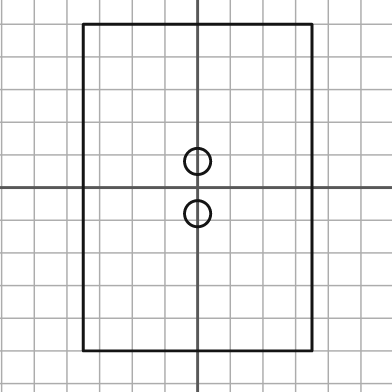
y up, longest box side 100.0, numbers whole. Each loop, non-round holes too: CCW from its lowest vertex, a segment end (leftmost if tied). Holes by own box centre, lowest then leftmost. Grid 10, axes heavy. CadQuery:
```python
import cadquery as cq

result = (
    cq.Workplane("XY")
    .moveTo(-35.0, -50.0)
    .lineTo(35.0, -50.0)
    .lineTo(35.0, 50.0)
    .lineTo(-35.0, 50.0)
    .close()
    .moveTo(0.0, -8.0)
    .circle(4.0)
    .moveTo(0.0, 8.0)
    .circle(4.0)
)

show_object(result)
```